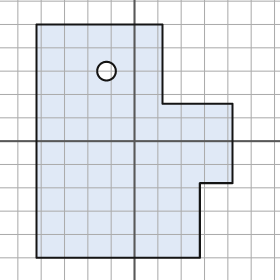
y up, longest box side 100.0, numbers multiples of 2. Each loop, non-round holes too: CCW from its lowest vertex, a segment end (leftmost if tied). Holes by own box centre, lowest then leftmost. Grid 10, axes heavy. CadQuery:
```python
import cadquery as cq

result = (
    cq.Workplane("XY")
    .moveTo(-42.0, -50.0)
    .lineTo(28.0, -50.0)
    .lineTo(28.0, -18.0)
    .lineTo(42.0, -18.0)
    .lineTo(42.0, 16.0)
    .lineTo(12.0, 16.0)
    .lineTo(12.0, 50.0)
    .lineTo(-42.0, 50.0)
    .close()
    .moveTo(-12.0, 30.0)
    .circle(4.0)
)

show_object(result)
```